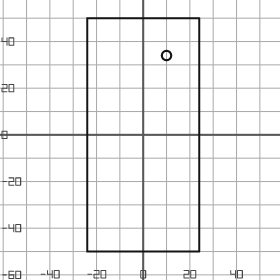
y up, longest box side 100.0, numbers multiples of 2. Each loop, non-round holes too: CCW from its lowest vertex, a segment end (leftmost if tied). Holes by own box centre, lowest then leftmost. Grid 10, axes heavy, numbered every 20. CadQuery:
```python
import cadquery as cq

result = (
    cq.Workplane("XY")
    .moveTo(-24.0, -50.0)
    .lineTo(24.0, -50.0)
    .lineTo(24.0, 50.0)
    .lineTo(-24.0, 50.0)
    .close()
    .moveTo(10.0, 34.0)
    .circle(2.0)
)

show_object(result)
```